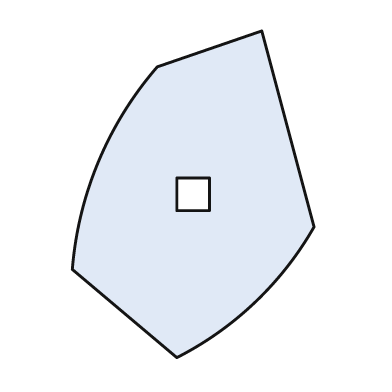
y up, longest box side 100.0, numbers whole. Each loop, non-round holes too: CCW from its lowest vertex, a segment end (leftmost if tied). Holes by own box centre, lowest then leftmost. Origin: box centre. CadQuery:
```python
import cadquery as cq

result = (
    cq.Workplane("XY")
    .moveTo(-5.0, -50.0)
    .threePointArc((19.0, -33.0), (37.0, -10.0))
    .lineTo(21.0, 50.0)
    .lineTo(-11.0, 39.0)
    .threePointArc((-29.0, 10.0), (-37.0, -23.0))
    .close()
    .moveTo(-5.0, -5.0)
    .lineTo(5.0, -5.0)
    .lineTo(5.0, 5.0)
    .lineTo(-5.0, 5.0)
    .close()
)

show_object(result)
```